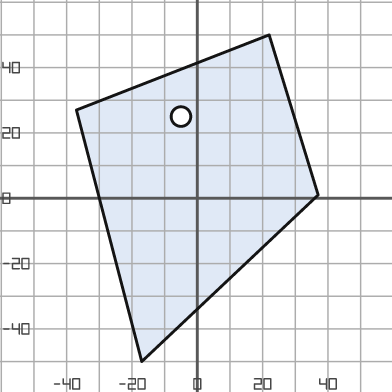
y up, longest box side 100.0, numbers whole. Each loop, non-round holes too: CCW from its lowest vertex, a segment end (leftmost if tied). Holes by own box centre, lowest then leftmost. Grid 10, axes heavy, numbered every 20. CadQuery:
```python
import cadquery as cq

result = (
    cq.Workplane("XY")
    .moveTo(-17.0, -50.0)
    .lineTo(37.0, 1.0)
    .lineTo(22.0, 50.0)
    .lineTo(-37.0, 27.0)
    .close()
    .moveTo(-5.0, 25.0)
    .circle(3.0)
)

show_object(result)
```